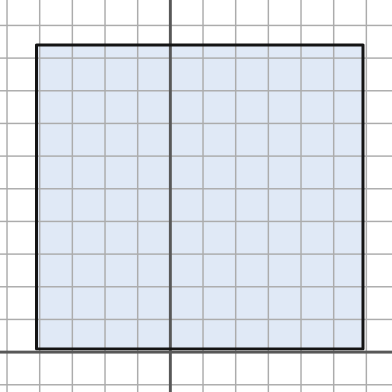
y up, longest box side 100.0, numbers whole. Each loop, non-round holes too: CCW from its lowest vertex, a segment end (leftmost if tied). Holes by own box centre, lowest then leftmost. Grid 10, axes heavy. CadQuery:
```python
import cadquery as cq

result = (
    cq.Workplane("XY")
    .moveTo(-41.0, 1.0)
    .lineTo(59.0, 1.0)
    .lineTo(59.0, 94.0)
    .lineTo(-41.0, 94.0)
    .close()
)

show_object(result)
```